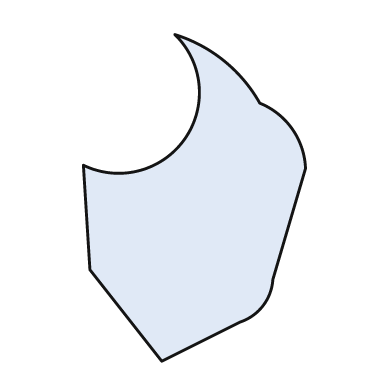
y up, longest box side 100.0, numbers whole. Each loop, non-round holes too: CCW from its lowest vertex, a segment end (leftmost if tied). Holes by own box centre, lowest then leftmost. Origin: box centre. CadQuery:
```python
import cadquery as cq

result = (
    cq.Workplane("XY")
    .moveTo(-10.0, -50.0)
    .lineTo(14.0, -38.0)
    .threePointArc((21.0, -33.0), (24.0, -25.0))
    .lineTo(34.0, 9.0)
    .threePointArc((30.0, 21.0), (20.0, 29.0))
    .threePointArc((9.0, 42.0), (-6.0, 50.0))
    .threePointArc((-3.0, 18.0), (-34.0, 10.0))
    .lineTo(-32.0, -22.0)
    .close()
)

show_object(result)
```